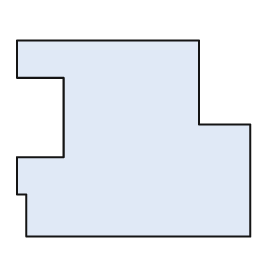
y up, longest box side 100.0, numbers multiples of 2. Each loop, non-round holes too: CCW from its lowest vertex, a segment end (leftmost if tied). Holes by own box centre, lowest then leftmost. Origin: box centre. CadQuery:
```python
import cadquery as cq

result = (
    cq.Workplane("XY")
    .moveTo(-46.0, -42.0)
    .lineTo(50.0, -42.0)
    .lineTo(50.0, 6.0)
    .lineTo(28.0, 6.0)
    .lineTo(28.0, 42.0)
    .lineTo(-50.0, 42.0)
    .lineTo(-50.0, 26.0)
    .lineTo(-30.0, 26.0)
    .lineTo(-30.0, -8.0)
    .lineTo(-50.0, -8.0)
    .lineTo(-50.0, -24.0)
    .lineTo(-46.0, -24.0)
    .close()
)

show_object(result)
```